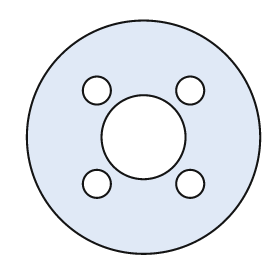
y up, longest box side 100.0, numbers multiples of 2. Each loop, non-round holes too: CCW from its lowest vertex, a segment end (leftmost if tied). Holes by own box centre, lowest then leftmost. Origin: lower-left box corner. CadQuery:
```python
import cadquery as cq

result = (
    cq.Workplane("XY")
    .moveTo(50.0, 50.0)
    .circle(50.0)
    .moveTo(30.0, 30.0)
    .circle(6.0)
    .moveTo(70.0, 30.0)
    .circle(6.0)
    .moveTo(50.0, 50.0)
    .circle(18.0)
    .moveTo(30.0, 70.0)
    .circle(6.0)
    .moveTo(70.0, 70.0)
    .circle(6.0)
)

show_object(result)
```